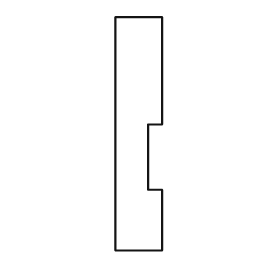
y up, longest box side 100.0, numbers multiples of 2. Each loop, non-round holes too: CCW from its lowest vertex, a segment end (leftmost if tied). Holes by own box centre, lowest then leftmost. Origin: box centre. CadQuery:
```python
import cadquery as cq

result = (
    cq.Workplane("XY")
    .moveTo(-10.0, -50.0)
    .lineTo(10.0, -50.0)
    .lineTo(10.0, -24.0)
    .lineTo(4.0, -24.0)
    .lineTo(4.0, 4.0)
    .lineTo(10.0, 4.0)
    .lineTo(10.0, 50.0)
    .lineTo(-10.0, 50.0)
    .close()
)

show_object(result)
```